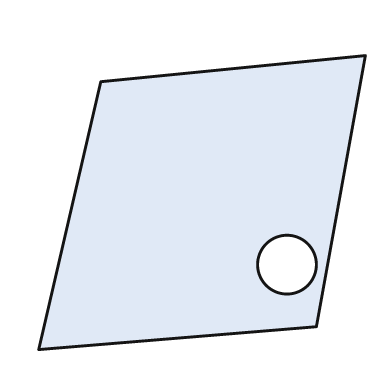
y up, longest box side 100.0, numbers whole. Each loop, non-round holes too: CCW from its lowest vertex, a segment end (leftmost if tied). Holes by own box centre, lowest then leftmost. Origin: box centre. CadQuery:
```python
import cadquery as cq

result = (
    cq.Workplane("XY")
    .moveTo(-50.0, -45.0)
    .lineTo(35.0, -38.0)
    .lineTo(50.0, 45.0)
    .lineTo(-31.0, 37.0)
    .close()
    .moveTo(26.0, -19.0)
    .circle(9.0)
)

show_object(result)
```